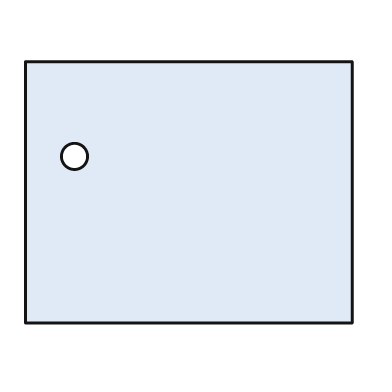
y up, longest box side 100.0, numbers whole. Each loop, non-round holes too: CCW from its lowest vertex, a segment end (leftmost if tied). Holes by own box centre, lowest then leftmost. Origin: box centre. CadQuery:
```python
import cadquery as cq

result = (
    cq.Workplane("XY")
    .moveTo(-50.0, -40.0)
    .lineTo(50.0, -40.0)
    .lineTo(50.0, 40.0)
    .lineTo(-50.0, 40.0)
    .close()
    .moveTo(-35.0, 11.0)
    .circle(4.0)
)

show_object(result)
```